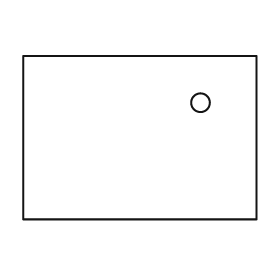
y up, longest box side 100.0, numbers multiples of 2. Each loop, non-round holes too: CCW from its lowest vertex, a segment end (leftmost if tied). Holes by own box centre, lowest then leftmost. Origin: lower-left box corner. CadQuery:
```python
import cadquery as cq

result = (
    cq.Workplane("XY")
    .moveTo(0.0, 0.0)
    .lineTo(100.0, 0.0)
    .lineTo(100.0, 70.0)
    .lineTo(0.0, 70.0)
    .close()
    .moveTo(76.0, 50.0)
    .circle(4.0)
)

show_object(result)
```